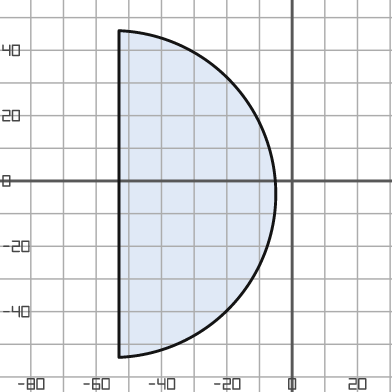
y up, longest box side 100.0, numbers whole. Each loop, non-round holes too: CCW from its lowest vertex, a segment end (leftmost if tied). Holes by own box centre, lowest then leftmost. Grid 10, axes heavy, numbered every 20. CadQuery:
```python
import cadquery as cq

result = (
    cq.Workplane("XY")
    .moveTo(-53.0, -54.0)
    .threePointArc((-5.0, -4.0), (-53.0, 46.0))
    .close()
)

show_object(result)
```